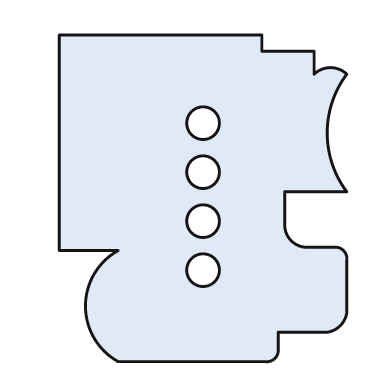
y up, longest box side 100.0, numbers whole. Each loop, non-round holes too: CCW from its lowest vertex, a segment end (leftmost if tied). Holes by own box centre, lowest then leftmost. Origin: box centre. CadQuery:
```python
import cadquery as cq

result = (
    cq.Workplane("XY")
    .moveTo(-26.0, -50.0)
    .lineTo(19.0, -50.0)
    .threePointArc((22.0, -49.0), (23.0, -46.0))
    .lineTo(23.0, -41.0)
    .lineTo(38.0, -41.0)
    .threePointArc((42.0, -39.0), (44.0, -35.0))
    .lineTo(44.0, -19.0)
    .threePointArc((43.0, -16.0), (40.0, -15.0))
    .lineTo(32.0, -15.0)
    .threePointArc((27.0, -13.0), (25.0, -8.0))
    .lineTo(25.0, 2.0)
    .lineTo(44.0, 2.0)
    .threePointArc((38.0, 20.0), (44.0, 38.0))
    .threePointArc((39.0, 40.0), (34.0, 38.0))
    .lineTo(34.0, 45.0)
    .lineTo(18.0, 45.0)
    .lineTo(18.0, 50.0)
    .lineTo(-44.0, 50.0)
    .lineTo(-44.0, -16.0)
    .lineTo(-26.0, -16.0)
    .threePointArc((-36.0, -33.0), (-26.0, -50.0))
    .close()
    .moveTo(0.0, -22.0)
    .circle(5.0)
    .moveTo(0.0, -7.0)
    .circle(5.0)
    .moveTo(0.0, 8.0)
    .circle(5.0)
    .moveTo(0.0, 23.0)
    .circle(5.0)
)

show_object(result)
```